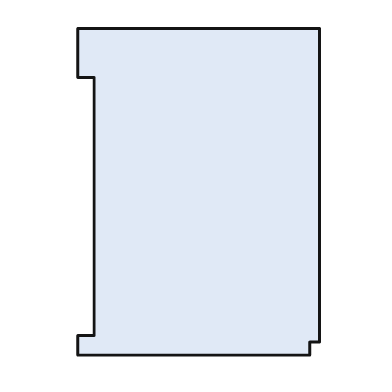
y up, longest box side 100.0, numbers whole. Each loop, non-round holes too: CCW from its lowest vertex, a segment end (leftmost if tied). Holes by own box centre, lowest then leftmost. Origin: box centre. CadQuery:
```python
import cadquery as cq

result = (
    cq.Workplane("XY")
    .moveTo(-37.0, -50.0)
    .lineTo(34.0, -50.0)
    .lineTo(34.0, -46.0)
    .lineTo(37.0, -46.0)
    .lineTo(37.0, 50.0)
    .lineTo(-37.0, 50.0)
    .lineTo(-37.0, 35.0)
    .lineTo(-32.0, 35.0)
    .lineTo(-32.0, -44.0)
    .lineTo(-37.0, -44.0)
    .close()
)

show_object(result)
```